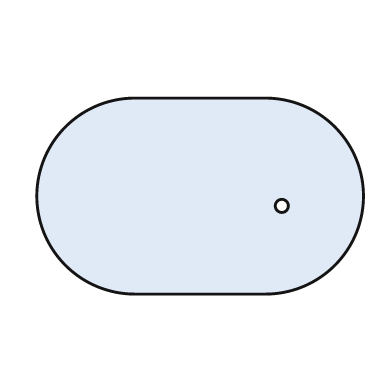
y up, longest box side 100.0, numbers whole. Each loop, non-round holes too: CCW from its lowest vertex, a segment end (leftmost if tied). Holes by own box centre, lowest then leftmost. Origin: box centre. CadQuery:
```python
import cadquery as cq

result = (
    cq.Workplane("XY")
    .moveTo(-20.0, -30.0)
    .lineTo(20.0, -30.0)
    .threePointArc((50.0, 0.0), (20.0, 30.0))
    .lineTo(-20.0, 30.0)
    .threePointArc((-50.0, 0.0), (-20.0, -30.0))
    .close()
    .moveTo(25.0, -3.0)
    .circle(2.0)
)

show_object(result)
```